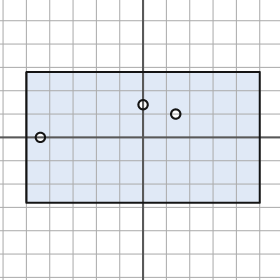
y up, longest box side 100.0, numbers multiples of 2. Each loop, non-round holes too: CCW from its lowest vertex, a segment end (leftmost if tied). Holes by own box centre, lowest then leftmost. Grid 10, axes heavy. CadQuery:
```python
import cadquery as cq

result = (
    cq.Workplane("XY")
    .moveTo(-50.0, -28.0)
    .lineTo(50.0, -28.0)
    .lineTo(50.0, 28.0)
    .lineTo(-50.0, 28.0)
    .close()
    .moveTo(-44.0, 0.0)
    .circle(2.0)
    .moveTo(14.0, 10.0)
    .circle(2.0)
    .moveTo(0.0, 14.0)
    .circle(2.0)
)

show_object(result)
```